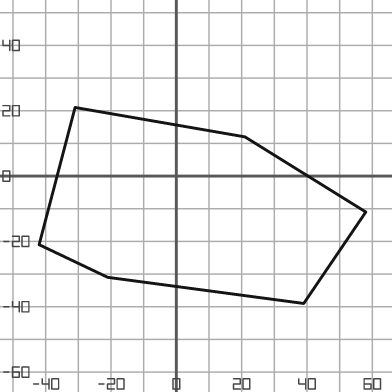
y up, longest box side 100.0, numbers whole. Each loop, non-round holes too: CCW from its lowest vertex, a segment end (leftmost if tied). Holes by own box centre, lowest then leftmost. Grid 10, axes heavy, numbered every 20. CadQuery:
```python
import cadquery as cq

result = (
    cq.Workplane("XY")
    .moveTo(39.0, -39.0)
    .lineTo(58.0, -11.0)
    .lineTo(21.0, 12.0)
    .lineTo(-31.0, 21.0)
    .lineTo(-42.0, -21.0)
    .lineTo(-21.0, -31.0)
    .close()
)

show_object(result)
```